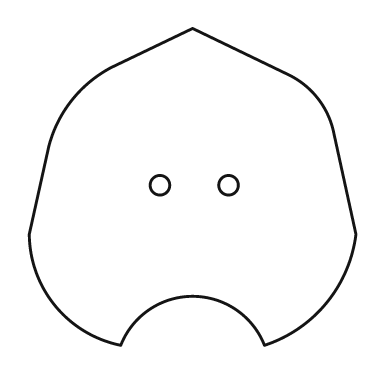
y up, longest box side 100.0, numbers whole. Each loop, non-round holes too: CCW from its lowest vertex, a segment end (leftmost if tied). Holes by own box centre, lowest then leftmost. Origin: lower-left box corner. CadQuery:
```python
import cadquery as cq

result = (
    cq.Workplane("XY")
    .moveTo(28.0, 0.0)
    .threePointArc((50.0, 15.0), (72.0, 0.0))
    .threePointArc((91.0, 13.0), (100.0, 34.0))
    .lineTo(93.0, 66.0)
    .threePointArc((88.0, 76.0), (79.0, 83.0))
    .lineTo(50.0, 97.0)
    .lineTo(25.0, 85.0)
    .threePointArc((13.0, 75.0), (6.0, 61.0))
    .lineTo(0.0, 34.0)
    .threePointArc((8.0, 12.0), (28.0, 0.0))
    .close()
    .moveTo(40.0, 49.0)
    .circle(3.0)
    .moveTo(61.0, 49.0)
    .circle(3.0)
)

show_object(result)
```